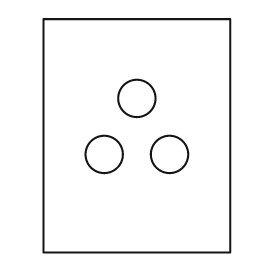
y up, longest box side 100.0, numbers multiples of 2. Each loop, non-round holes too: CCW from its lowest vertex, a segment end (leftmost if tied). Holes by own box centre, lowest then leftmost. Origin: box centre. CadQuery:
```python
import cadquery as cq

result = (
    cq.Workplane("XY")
    .moveTo(-40.0, -50.0)
    .lineTo(40.0, -50.0)
    .lineTo(40.0, 50.0)
    .lineTo(-40.0, 50.0)
    .close()
    .moveTo(-14.0, -8.0)
    .circle(8.0)
    .moveTo(14.0, -8.0)
    .circle(8.0)
    .moveTo(0.0, 16.0)
    .circle(8.0)
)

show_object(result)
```